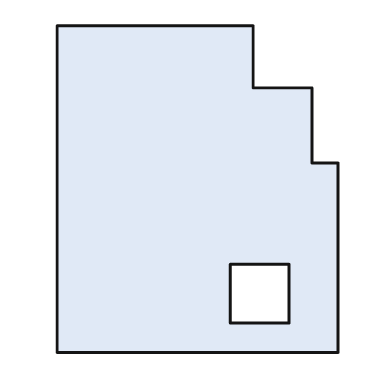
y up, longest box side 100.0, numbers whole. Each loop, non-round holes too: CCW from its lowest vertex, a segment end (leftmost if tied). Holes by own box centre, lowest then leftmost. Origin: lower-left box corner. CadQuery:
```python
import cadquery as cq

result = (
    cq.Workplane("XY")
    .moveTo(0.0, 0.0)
    .lineTo(86.0, 0.0)
    .lineTo(86.0, 58.0)
    .lineTo(78.0, 58.0)
    .lineTo(78.0, 81.0)
    .lineTo(60.0, 81.0)
    .lineTo(60.0, 100.0)
    .lineTo(0.0, 100.0)
    .close()
    .moveTo(53.0, 9.0)
    .lineTo(71.0, 9.0)
    .lineTo(71.0, 27.0)
    .lineTo(53.0, 27.0)
    .close()
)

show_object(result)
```